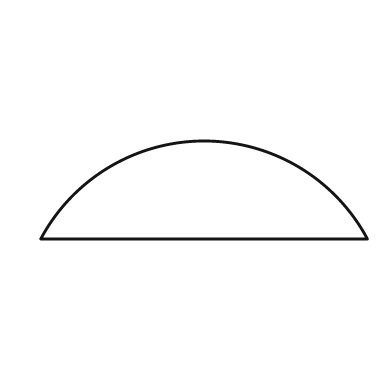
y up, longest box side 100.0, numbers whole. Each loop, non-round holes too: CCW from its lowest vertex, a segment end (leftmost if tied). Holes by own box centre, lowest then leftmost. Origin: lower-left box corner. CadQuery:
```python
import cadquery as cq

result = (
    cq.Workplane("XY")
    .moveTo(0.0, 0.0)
    .lineTo(100.0, 0.0)
    .threePointArc((50.0, 30.0), (0.0, 0.0))
    .close()
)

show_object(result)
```